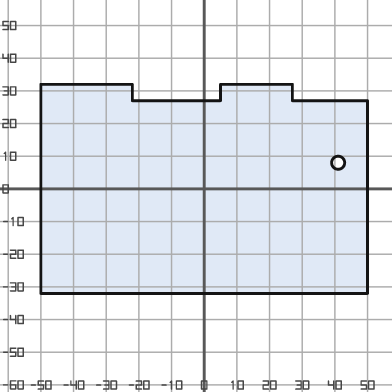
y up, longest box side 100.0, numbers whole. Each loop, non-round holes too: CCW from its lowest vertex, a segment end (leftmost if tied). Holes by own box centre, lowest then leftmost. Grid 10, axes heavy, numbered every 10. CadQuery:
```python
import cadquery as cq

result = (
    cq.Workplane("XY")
    .moveTo(-50.0, -32.0)
    .lineTo(50.0, -32.0)
    .lineTo(50.0, 27.0)
    .lineTo(27.0, 27.0)
    .lineTo(27.0, 32.0)
    .lineTo(5.0, 32.0)
    .lineTo(5.0, 27.0)
    .lineTo(-22.0, 27.0)
    .lineTo(-22.0, 32.0)
    .lineTo(-50.0, 32.0)
    .close()
    .moveTo(41.0, 8.0)
    .circle(2.0)
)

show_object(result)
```